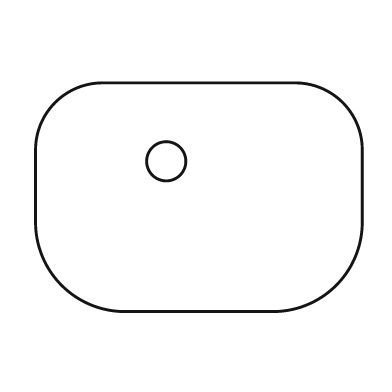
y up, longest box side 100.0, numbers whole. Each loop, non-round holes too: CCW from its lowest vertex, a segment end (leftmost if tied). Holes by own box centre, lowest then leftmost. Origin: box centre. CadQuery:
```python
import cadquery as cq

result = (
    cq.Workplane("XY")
    .moveTo(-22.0, -35.0)
    .lineTo(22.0, -35.0)
    .threePointArc((42.0, -27.0), (50.0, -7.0))
    .lineTo(50.0, 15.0)
    .threePointArc((44.0, 29.0), (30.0, 35.0))
    .lineTo(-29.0, 35.0)
    .threePointArc((-44.0, 29.0), (-50.0, 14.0))
    .lineTo(-50.0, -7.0)
    .threePointArc((-42.0, -27.0), (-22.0, -35.0))
    .close()
    .moveTo(-10.0, 11.0)
    .circle(6.0)
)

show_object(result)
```